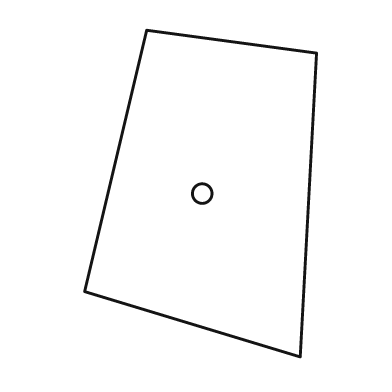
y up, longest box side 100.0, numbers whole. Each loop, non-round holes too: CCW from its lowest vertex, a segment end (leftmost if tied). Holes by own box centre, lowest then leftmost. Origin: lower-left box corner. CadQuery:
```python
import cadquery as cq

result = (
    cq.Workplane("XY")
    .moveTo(66.0, 0.0)
    .lineTo(71.0, 93.0)
    .lineTo(19.0, 100.0)
    .lineTo(0.0, 20.0)
    .close()
    .moveTo(36.0, 50.0)
    .circle(3.0)
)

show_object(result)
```